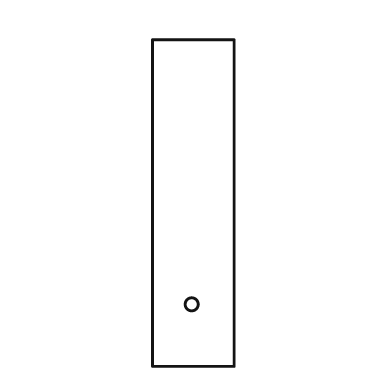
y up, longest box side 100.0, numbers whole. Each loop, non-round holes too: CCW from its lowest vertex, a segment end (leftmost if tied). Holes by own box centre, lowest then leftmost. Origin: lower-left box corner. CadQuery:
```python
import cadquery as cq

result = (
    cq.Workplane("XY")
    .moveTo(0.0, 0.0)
    .lineTo(25.0, 0.0)
    .lineTo(25.0, 100.0)
    .lineTo(0.0, 100.0)
    .close()
    .moveTo(12.0, 19.0)
    .circle(2.0)
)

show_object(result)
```